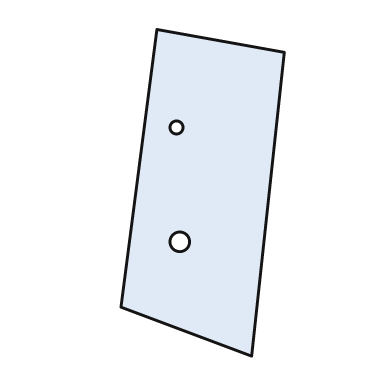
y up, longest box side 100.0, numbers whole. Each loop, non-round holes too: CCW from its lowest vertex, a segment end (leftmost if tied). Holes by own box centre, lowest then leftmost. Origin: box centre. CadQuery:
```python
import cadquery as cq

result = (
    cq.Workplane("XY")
    .moveTo(15.0, -50.0)
    .lineTo(25.0, 43.0)
    .lineTo(-14.0, 50.0)
    .lineTo(-25.0, -35.0)
    .close()
    .moveTo(-7.0, -15.0)
    .circle(3.0)
    .moveTo(-8.0, 20.0)
    .circle(2.0)
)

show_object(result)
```